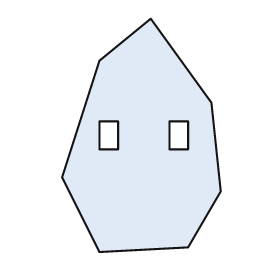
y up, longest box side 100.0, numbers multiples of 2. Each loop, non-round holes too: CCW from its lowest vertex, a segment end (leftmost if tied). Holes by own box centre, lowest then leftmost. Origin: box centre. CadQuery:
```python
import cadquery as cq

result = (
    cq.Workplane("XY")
    .moveTo(-18.0, -50.0)
    .lineTo(20.0, -48.0)
    .lineTo(34.0, -24.0)
    .lineTo(30.0, 14.0)
    .lineTo(4.0, 50.0)
    .lineTo(-18.0, 32.0)
    .lineTo(-34.0, -18.0)
    .close()
    .moveTo(-18.0, -6.0)
    .lineTo(-10.0, -6.0)
    .lineTo(-10.0, 6.0)
    .lineTo(-18.0, 6.0)
    .close()
    .moveTo(12.0, -6.0)
    .lineTo(20.0, -6.0)
    .lineTo(20.0, 6.0)
    .lineTo(12.0, 6.0)
    .close()
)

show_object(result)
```